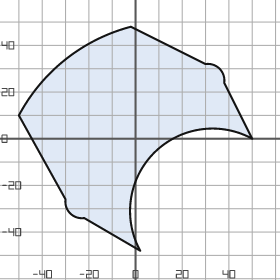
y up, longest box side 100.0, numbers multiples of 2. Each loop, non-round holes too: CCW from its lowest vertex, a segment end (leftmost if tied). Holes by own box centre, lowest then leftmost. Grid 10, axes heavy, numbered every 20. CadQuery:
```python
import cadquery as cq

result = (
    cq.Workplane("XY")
    .moveTo(2.0, -48.0)
    .threePointArc((8.0, -6.0), (50.0, 0.0))
    .lineTo(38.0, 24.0)
    .threePointArc((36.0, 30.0), (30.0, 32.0))
    .lineTo(-2.0, 48.0)
    .threePointArc((-30.0, 34.0), (-50.0, 10.0))
    .lineTo(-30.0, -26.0)
    .threePointArc((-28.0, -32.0), (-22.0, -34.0))
    .close()
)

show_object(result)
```